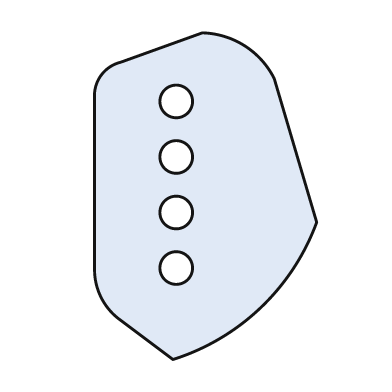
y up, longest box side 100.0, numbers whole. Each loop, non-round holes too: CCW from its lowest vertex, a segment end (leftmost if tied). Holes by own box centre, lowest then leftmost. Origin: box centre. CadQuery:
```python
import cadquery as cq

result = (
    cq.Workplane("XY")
    .moveTo(-10.0, -50.0)
    .threePointArc((17.0, -34.0), (34.0, -8.0))
    .lineTo(21.0, 36.0)
    .threePointArc((12.0, 46.0), (-1.0, 50.0))
    .lineTo(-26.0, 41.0)
    .threePointArc((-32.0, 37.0), (-34.0, 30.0))
    .lineTo(-34.0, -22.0)
    .threePointArc((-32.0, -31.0), (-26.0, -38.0))
    .close()
    .moveTo(-9.0, -22.0)
    .circle(5.0)
    .moveTo(-9.0, -5.0)
    .circle(5.0)
    .moveTo(-9.0, 12.0)
    .circle(5.0)
    .moveTo(-9.0, 29.0)
    .circle(5.0)
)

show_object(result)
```